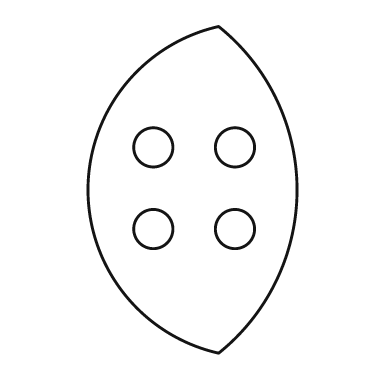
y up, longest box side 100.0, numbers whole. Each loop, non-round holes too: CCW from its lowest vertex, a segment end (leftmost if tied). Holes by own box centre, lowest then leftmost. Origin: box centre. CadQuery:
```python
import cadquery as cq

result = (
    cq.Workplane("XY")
    .moveTo(8.0, -50.0)
    .threePointArc((32.0, 0.0), (8.0, 50.0))
    .threePointArc((-32.0, 0.0), (8.0, -50.0))
    .close()
    .moveTo(-12.0, -12.0)
    .circle(6.0)
    .moveTo(13.0, -12.0)
    .circle(6.0)
    .moveTo(-12.0, 13.0)
    .circle(6.0)
    .moveTo(13.0, 13.0)
    .circle(6.0)
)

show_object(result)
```